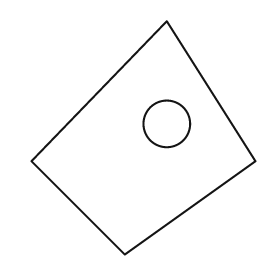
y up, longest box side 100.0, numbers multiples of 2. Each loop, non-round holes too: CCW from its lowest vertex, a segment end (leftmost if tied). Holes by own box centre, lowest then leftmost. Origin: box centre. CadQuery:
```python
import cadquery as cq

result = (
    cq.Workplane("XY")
    .moveTo(-8.0, -50.0)
    .lineTo(48.0, -10.0)
    .lineTo(10.0, 50.0)
    .lineTo(-48.0, -10.0)
    .close()
    .moveTo(10.0, 6.0)
    .circle(10.0)
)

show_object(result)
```